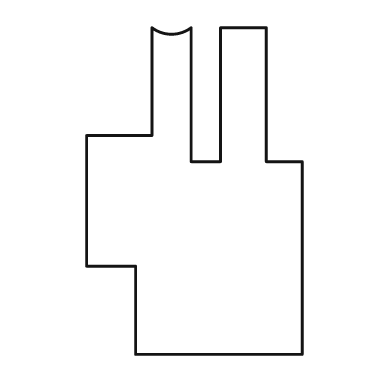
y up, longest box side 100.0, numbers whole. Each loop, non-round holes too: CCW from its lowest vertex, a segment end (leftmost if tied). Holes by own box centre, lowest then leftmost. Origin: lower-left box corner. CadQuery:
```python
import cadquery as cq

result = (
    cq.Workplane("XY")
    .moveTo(15.0, 0.0)
    .lineTo(66.0, 0.0)
    .lineTo(66.0, 59.0)
    .lineTo(55.0, 59.0)
    .lineTo(55.0, 100.0)
    .lineTo(41.0, 100.0)
    .lineTo(41.0, 59.0)
    .lineTo(32.0, 59.0)
    .lineTo(32.0, 100.0)
    .threePointArc((26.0, 98.0), (20.0, 100.0))
    .lineTo(20.0, 67.0)
    .lineTo(0.0, 67.0)
    .lineTo(0.0, 27.0)
    .lineTo(15.0, 27.0)
    .close()
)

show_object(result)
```